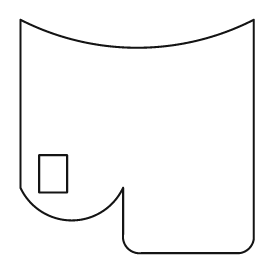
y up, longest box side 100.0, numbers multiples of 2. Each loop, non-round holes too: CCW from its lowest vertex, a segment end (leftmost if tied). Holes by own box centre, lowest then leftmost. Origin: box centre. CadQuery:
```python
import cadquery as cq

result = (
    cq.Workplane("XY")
    .moveTo(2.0, -50.0)
    .lineTo(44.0, -50.0)
    .threePointArc((48.0, -48.0), (50.0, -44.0))
    .lineTo(50.0, 50.0)
    .threePointArc((0.0, 38.0), (-50.0, 50.0))
    .lineTo(-50.0, -22.0)
    .threePointArc((-28.0, -36.0), (-6.0, -22.0))
    .lineTo(-6.0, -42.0)
    .threePointArc((-4.0, -48.0), (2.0, -50.0))
    .close()
    .moveTo(-42.0, -24.0)
    .lineTo(-30.0, -24.0)
    .lineTo(-30.0, -8.0)
    .lineTo(-42.0, -8.0)
    .close()
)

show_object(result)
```